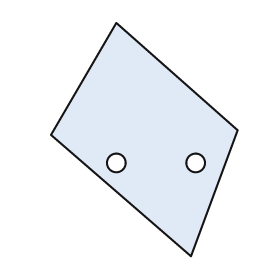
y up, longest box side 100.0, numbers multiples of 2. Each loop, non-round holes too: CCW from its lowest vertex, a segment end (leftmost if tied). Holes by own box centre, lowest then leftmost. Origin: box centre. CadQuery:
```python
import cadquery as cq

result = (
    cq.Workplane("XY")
    .moveTo(20.0, -50.0)
    .lineTo(40.0, 4.0)
    .lineTo(-12.0, 50.0)
    .lineTo(-40.0, 2.0)
    .close()
    .moveTo(-12.0, -10.0)
    .circle(4.0)
    .moveTo(22.0, -10.0)
    .circle(4.0)
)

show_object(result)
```